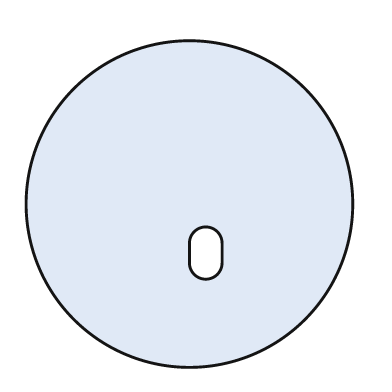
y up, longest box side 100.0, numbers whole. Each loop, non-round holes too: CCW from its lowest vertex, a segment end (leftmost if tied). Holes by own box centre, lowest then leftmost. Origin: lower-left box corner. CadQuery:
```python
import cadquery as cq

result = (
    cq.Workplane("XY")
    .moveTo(50.0, 50.0)
    .circle(50.0)
    .moveTo(50.0, 32.0)
    .threePointArc((55.0, 27.0), (60.0, 32.0))
    .lineTo(60.0, 38.0)
    .threePointArc((55.0, 43.0), (50.0, 38.0))
    .close()
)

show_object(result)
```